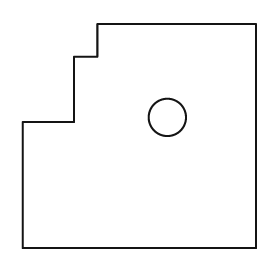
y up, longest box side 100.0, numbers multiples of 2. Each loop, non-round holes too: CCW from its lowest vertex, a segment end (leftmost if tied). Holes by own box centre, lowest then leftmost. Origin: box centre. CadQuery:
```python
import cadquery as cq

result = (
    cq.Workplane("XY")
    .moveTo(-50.0, -48.0)
    .lineTo(50.0, -48.0)
    .lineTo(50.0, 48.0)
    .lineTo(-18.0, 48.0)
    .lineTo(-18.0, 34.0)
    .lineTo(-28.0, 34.0)
    .lineTo(-28.0, 6.0)
    .lineTo(-50.0, 6.0)
    .close()
    .moveTo(12.0, 8.0)
    .circle(8.0)
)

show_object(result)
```